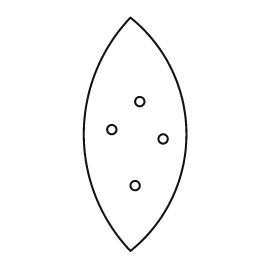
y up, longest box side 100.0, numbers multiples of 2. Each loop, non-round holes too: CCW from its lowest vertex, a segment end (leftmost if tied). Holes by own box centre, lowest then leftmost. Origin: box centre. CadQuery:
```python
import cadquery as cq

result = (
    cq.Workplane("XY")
    .moveTo(-2.0, -50.0)
    .threePointArc((22.0, 0.0), (-2.0, 50.0))
    .threePointArc((-22.0, 0.0), (-2.0, -50.0))
    .close()
    .moveTo(0.0, -22.0)
    .circle(2.0)
    .moveTo(12.0, -2.0)
    .circle(2.0)
    .moveTo(-10.0, 2.0)
    .circle(2.0)
    .moveTo(2.0, 14.0)
    .circle(2.0)
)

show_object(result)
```